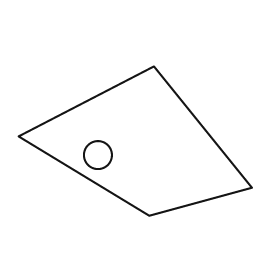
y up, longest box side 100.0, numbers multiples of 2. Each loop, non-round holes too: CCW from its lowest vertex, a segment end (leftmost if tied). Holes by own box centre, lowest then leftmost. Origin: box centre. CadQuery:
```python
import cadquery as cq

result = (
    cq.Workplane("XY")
    .moveTo(6.0, -32.0)
    .lineTo(50.0, -20.0)
    .lineTo(8.0, 32.0)
    .lineTo(-50.0, 2.0)
    .close()
    .moveTo(-16.0, -6.0)
    .circle(6.0)
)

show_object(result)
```